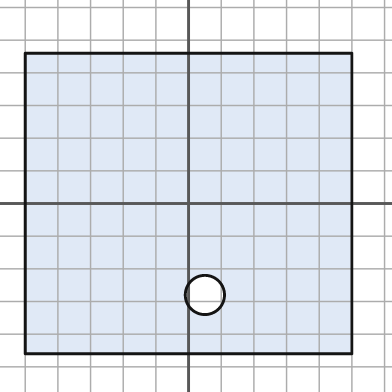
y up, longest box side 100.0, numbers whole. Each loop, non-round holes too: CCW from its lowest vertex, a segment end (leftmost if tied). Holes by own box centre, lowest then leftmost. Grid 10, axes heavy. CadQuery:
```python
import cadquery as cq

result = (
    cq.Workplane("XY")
    .moveTo(-50.0, -46.0)
    .lineTo(50.0, -46.0)
    .lineTo(50.0, 46.0)
    .lineTo(-50.0, 46.0)
    .close()
    .moveTo(5.0, -28.0)
    .circle(6.0)
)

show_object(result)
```